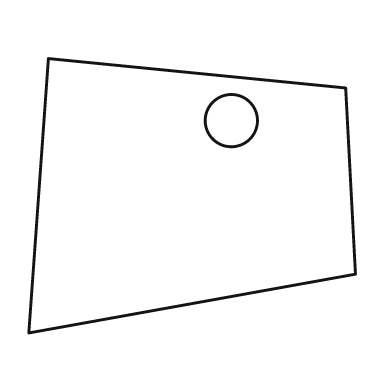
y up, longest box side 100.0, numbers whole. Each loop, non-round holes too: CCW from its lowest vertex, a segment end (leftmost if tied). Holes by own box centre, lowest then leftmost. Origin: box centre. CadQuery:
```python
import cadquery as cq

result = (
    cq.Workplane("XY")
    .moveTo(-50.0, -42.0)
    .lineTo(50.0, -24.0)
    .lineTo(47.0, 33.0)
    .lineTo(-44.0, 42.0)
    .close()
    .moveTo(12.0, 23.0)
    .circle(8.0)
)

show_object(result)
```